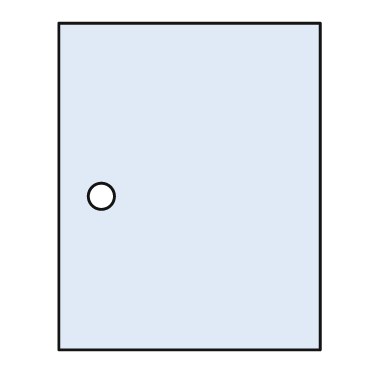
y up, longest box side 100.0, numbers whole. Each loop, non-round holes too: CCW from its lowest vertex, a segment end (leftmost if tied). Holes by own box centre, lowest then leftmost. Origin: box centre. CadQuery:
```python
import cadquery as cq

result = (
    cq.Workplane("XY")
    .moveTo(-40.0, -50.0)
    .lineTo(40.0, -50.0)
    .lineTo(40.0, 50.0)
    .lineTo(-40.0, 50.0)
    .close()
    .moveTo(-27.0, -3.0)
    .circle(4.0)
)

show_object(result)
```